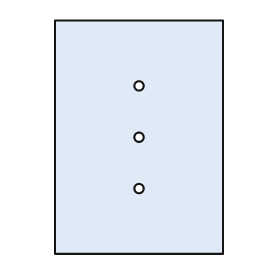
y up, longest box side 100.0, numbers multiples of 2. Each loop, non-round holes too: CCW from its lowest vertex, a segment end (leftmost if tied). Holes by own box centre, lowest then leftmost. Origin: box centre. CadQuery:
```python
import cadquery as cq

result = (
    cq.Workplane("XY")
    .moveTo(-36.0, -50.0)
    .lineTo(36.0, -50.0)
    .lineTo(36.0, 50.0)
    .lineTo(-36.0, 50.0)
    .close()
    .moveTo(0.0, -22.0)
    .circle(2.0)
    .moveTo(0.0, 0.0)
    .circle(2.0)
    .moveTo(0.0, 22.0)
    .circle(2.0)
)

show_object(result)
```